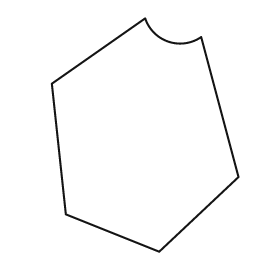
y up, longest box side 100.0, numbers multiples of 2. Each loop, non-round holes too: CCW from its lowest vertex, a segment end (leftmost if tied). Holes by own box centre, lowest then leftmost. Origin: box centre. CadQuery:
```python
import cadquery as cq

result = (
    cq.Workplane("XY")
    .moveTo(6.0, -50.0)
    .lineTo(40.0, -18.0)
    .lineTo(24.0, 42.0)
    .threePointArc((10.0, 40.0), (0.0, 50.0))
    .lineTo(-40.0, 22.0)
    .lineTo(-34.0, -34.0)
    .close()
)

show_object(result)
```